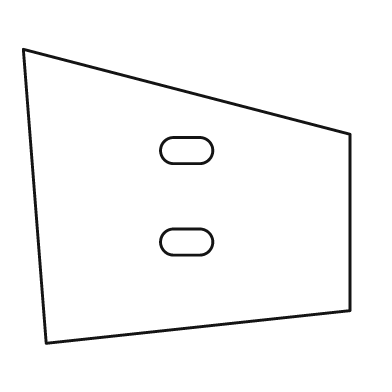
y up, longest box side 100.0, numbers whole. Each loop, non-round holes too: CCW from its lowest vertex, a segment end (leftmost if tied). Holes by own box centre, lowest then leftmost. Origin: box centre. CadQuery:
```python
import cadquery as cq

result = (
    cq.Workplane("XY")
    .moveTo(-43.0, -45.0)
    .lineTo(50.0, -35.0)
    .lineTo(50.0, 19.0)
    .lineTo(-50.0, 45.0)
    .close()
    .moveTo(-4.0, -18.0)
    .lineTo(4.0, -18.0)
    .threePointArc((8.0, -14.0), (4.0, -10.0))
    .lineTo(-4.0, -10.0)
    .threePointArc((-8.0, -14.0), (-4.0, -18.0))
    .close()
    .moveTo(-4.0, 10.0)
    .lineTo(4.0, 10.0)
    .threePointArc((8.0, 14.0), (4.0, 18.0))
    .lineTo(-4.0, 18.0)
    .threePointArc((-8.0, 14.0), (-4.0, 10.0))
    .close()
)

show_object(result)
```